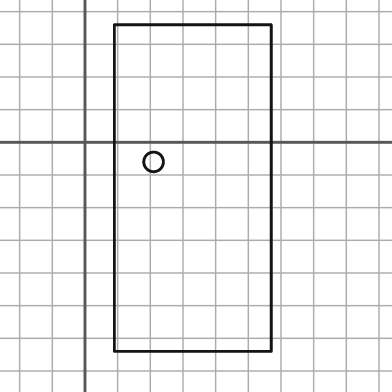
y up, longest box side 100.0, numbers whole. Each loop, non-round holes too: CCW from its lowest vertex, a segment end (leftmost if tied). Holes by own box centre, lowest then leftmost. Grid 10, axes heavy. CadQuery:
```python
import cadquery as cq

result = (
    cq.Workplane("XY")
    .moveTo(9.0, -64.0)
    .lineTo(57.0, -64.0)
    .lineTo(57.0, 36.0)
    .lineTo(9.0, 36.0)
    .close()
    .moveTo(21.0, -6.0)
    .circle(3.0)
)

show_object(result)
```